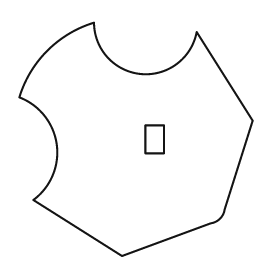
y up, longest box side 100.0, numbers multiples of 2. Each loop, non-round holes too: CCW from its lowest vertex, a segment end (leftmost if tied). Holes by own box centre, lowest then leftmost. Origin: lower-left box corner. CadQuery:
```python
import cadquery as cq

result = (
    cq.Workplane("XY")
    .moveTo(44.0, 0.0)
    .lineTo(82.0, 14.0)
    .threePointArc((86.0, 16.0), (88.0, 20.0))
    .lineTo(100.0, 58.0)
    .lineTo(76.0, 96.0)
    .threePointArc((52.0, 78.0), (32.0, 100.0))
    .threePointArc((12.0, 88.0), (0.0, 68.0))
    .threePointArc((16.0, 48.0), (6.0, 24.0))
    .close()
    .moveTo(54.0, 44.0)
    .lineTo(62.0, 44.0)
    .lineTo(62.0, 56.0)
    .lineTo(54.0, 56.0)
    .close()
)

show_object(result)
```